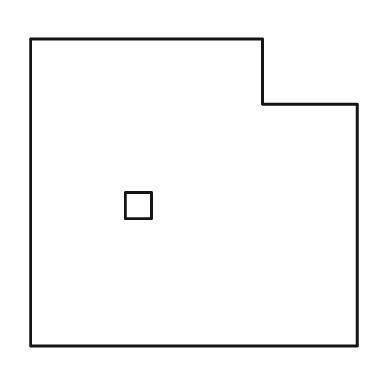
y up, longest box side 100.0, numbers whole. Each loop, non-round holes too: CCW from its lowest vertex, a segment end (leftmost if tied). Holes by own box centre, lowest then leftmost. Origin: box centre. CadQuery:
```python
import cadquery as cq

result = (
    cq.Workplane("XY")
    .moveTo(-50.0, -47.0)
    .lineTo(50.0, -47.0)
    .lineTo(50.0, 27.0)
    .lineTo(21.0, 27.0)
    .lineTo(21.0, 47.0)
    .lineTo(-50.0, 47.0)
    .close()
    .moveTo(-21.0, -8.0)
    .lineTo(-13.0, -8.0)
    .lineTo(-13.0, 0.0)
    .lineTo(-21.0, 0.0)
    .close()
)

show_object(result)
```